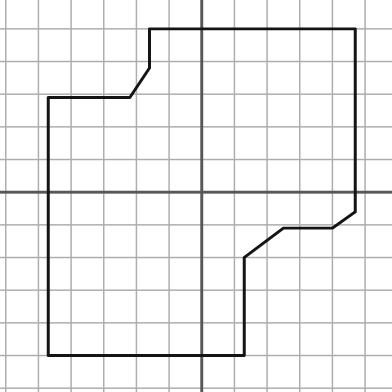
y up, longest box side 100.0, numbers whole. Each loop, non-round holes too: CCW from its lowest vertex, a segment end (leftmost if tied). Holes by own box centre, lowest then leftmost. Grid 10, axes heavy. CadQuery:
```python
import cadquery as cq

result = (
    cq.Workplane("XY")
    .moveTo(-47.0, -50.0)
    .lineTo(13.0, -50.0)
    .lineTo(13.0, -20.0)
    .lineTo(25.0, -11.0)
    .lineTo(40.0, -11.0)
    .lineTo(47.0, -6.0)
    .lineTo(47.0, 50.0)
    .lineTo(-16.0, 50.0)
    .lineTo(-16.0, 38.0)
    .lineTo(-22.0, 29.0)
    .lineTo(-47.0, 29.0)
    .close()
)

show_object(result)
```